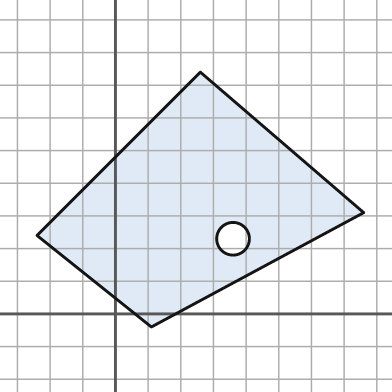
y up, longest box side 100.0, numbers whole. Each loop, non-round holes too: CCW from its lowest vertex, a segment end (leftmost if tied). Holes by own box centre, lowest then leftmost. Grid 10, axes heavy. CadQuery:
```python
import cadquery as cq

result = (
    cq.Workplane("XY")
    .moveTo(11.0, -4.0)
    .lineTo(76.0, 31.0)
    .lineTo(26.0, 74.0)
    .lineTo(-24.0, 24.0)
    .close()
    .moveTo(36.0, 23.0)
    .circle(5.0)
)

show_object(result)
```